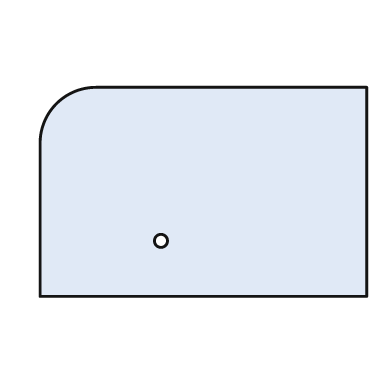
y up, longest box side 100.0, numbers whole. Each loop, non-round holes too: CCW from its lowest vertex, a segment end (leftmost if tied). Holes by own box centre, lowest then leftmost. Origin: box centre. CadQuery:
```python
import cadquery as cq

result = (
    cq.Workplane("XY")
    .moveTo(-50.0, -32.0)
    .lineTo(50.0, -32.0)
    .lineTo(50.0, 32.0)
    .lineTo(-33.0, 32.0)
    .threePointArc((-45.0, 27.0), (-50.0, 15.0))
    .close()
    .moveTo(-13.0, -15.0)
    .circle(2.0)
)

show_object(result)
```